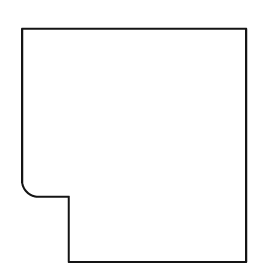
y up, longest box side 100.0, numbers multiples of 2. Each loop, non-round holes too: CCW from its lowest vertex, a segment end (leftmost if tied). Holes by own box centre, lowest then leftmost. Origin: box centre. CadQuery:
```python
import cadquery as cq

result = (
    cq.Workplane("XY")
    .moveTo(-28.0, -50.0)
    .lineTo(48.0, -50.0)
    .lineTo(48.0, 50.0)
    .lineTo(-48.0, 50.0)
    .lineTo(-48.0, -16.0)
    .threePointArc((-46.0, -20.0), (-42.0, -22.0))
    .lineTo(-28.0, -22.0)
    .close()
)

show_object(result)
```